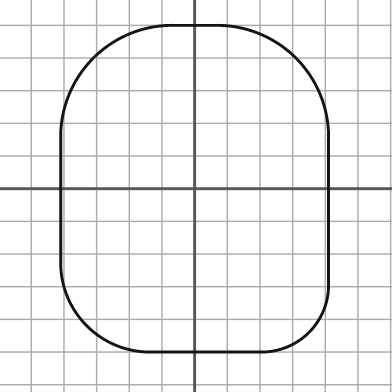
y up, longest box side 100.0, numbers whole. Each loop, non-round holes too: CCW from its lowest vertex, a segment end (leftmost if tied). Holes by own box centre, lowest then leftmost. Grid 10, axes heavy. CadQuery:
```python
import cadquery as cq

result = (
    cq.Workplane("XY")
    .moveTo(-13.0, -50.0)
    .lineTo(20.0, -50.0)
    .threePointArc((35.0, -44.0), (41.0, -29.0))
    .lineTo(41.0, 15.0)
    .threePointArc((31.0, 40.0), (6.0, 50.0))
    .lineTo(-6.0, 50.0)
    .threePointArc((-31.0, 40.0), (-41.0, 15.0))
    .lineTo(-41.0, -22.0)
    .threePointArc((-33.0, -42.0), (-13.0, -50.0))
    .close()
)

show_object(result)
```